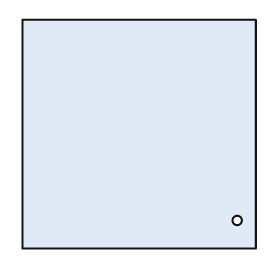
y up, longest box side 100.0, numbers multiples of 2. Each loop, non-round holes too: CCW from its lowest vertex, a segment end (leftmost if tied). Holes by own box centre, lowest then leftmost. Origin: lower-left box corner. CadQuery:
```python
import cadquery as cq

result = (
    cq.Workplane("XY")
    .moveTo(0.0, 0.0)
    .lineTo(100.0, 0.0)
    .lineTo(100.0, 98.0)
    .lineTo(0.0, 98.0)
    .close()
    .moveTo(92.0, 12.0)
    .circle(2.0)
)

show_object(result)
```